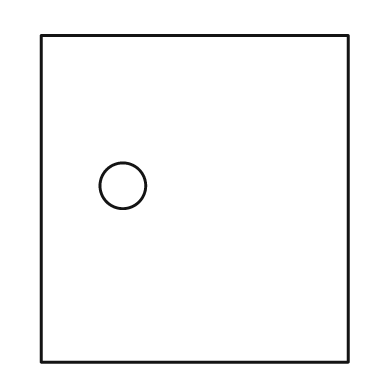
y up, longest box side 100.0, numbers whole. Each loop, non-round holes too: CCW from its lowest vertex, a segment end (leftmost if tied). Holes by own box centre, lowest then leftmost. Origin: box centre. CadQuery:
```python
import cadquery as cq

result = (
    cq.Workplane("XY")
    .moveTo(-47.0, -50.0)
    .lineTo(47.0, -50.0)
    .lineTo(47.0, 50.0)
    .lineTo(-47.0, 50.0)
    .close()
    .moveTo(-22.0, 4.0)
    .circle(7.0)
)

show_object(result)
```